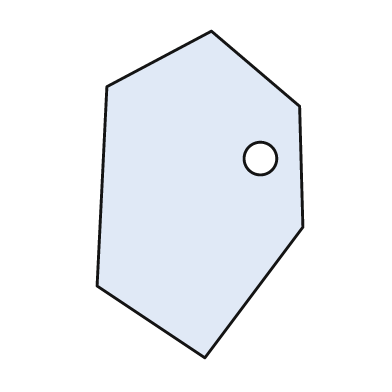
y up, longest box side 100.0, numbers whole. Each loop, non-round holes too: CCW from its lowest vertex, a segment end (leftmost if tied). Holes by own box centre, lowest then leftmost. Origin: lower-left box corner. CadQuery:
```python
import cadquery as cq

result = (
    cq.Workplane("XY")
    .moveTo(33.0, 0.0)
    .lineTo(63.0, 40.0)
    .lineTo(62.0, 77.0)
    .lineTo(35.0, 100.0)
    .lineTo(3.0, 83.0)
    .lineTo(0.0, 22.0)
    .close()
    .moveTo(50.0, 61.0)
    .circle(5.0)
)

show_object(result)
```